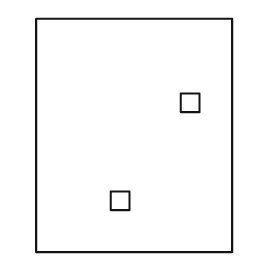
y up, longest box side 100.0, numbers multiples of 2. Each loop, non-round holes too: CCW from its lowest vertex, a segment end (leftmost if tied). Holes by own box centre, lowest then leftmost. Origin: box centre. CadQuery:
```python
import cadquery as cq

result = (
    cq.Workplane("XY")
    .moveTo(-42.0, -50.0)
    .lineTo(42.0, -50.0)
    .lineTo(42.0, 50.0)
    .lineTo(-42.0, 50.0)
    .close()
    .moveTo(-10.0, -32.0)
    .lineTo(-2.0, -32.0)
    .lineTo(-2.0, -24.0)
    .lineTo(-10.0, -24.0)
    .close()
    .moveTo(20.0, 10.0)
    .lineTo(28.0, 10.0)
    .lineTo(28.0, 18.0)
    .lineTo(20.0, 18.0)
    .close()
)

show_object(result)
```